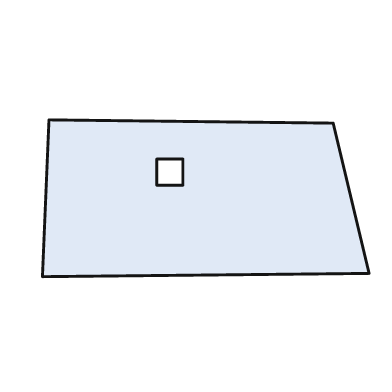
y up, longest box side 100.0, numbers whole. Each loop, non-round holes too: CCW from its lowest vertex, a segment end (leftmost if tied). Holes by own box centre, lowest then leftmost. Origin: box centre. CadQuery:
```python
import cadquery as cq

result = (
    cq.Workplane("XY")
    .moveTo(-50.0, -24.0)
    .lineTo(50.0, -23.0)
    .lineTo(39.0, 23.0)
    .lineTo(-48.0, 24.0)
    .close()
    .moveTo(-15.0, 4.0)
    .lineTo(-7.0, 4.0)
    .lineTo(-7.0, 12.0)
    .lineTo(-15.0, 12.0)
    .close()
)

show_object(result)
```